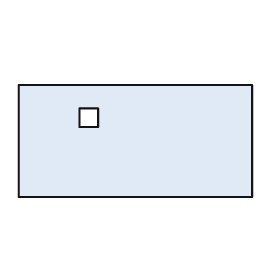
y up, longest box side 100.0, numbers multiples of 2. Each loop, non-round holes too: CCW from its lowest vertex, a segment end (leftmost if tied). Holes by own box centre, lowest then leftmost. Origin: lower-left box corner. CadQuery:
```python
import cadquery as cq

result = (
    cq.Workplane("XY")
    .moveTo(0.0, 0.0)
    .lineTo(100.0, 0.0)
    .lineTo(100.0, 48.0)
    .lineTo(0.0, 48.0)
    .close()
    .moveTo(26.0, 30.0)
    .lineTo(34.0, 30.0)
    .lineTo(34.0, 38.0)
    .lineTo(26.0, 38.0)
    .close()
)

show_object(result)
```